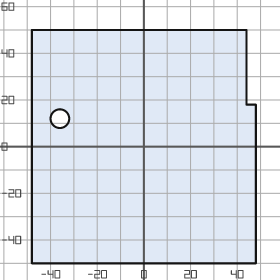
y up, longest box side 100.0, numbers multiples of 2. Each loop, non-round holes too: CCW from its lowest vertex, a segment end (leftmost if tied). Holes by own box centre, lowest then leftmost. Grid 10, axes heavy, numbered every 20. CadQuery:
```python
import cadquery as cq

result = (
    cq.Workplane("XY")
    .moveTo(-48.0, -50.0)
    .lineTo(48.0, -50.0)
    .lineTo(48.0, 18.0)
    .lineTo(44.0, 18.0)
    .lineTo(44.0, 50.0)
    .lineTo(-48.0, 50.0)
    .close()
    .moveTo(-36.0, 12.0)
    .circle(4.0)
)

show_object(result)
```